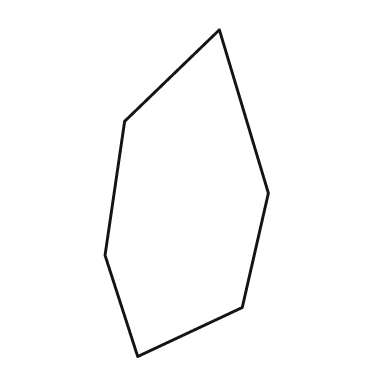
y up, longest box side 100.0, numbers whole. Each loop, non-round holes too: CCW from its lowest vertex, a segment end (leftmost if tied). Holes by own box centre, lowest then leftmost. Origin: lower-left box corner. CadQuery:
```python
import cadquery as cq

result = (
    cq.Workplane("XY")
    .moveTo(10.0, 0.0)
    .lineTo(42.0, 15.0)
    .lineTo(50.0, 50.0)
    .lineTo(35.0, 100.0)
    .lineTo(6.0, 72.0)
    .lineTo(0.0, 31.0)
    .close()
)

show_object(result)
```